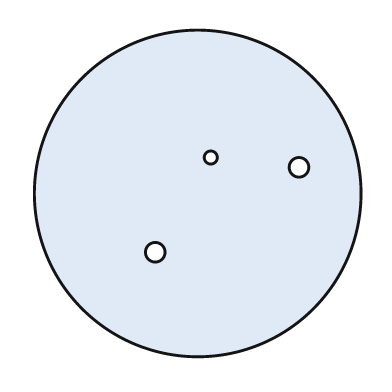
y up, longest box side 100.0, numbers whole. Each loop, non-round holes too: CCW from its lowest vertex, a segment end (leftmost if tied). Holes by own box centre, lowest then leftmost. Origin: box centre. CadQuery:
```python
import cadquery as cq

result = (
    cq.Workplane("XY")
    .moveTo(0.0, 0.0)
    .circle(50.0)
    .moveTo(-13.0, -18.0)
    .circle(3.0)
    .moveTo(31.0, 8.0)
    .circle(3.0)
    .moveTo(4.0, 11.0)
    .circle(2.0)
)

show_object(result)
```